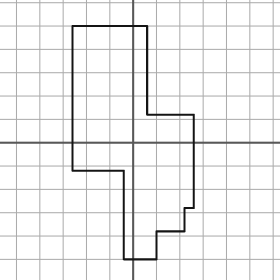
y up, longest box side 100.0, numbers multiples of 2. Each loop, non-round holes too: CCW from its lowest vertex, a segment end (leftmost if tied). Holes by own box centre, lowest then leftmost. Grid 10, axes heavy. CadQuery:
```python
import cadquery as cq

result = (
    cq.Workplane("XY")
    .moveTo(-4.0, -50.0)
    .lineTo(10.0, -50.0)
    .lineTo(10.0, -38.0)
    .lineTo(22.0, -38.0)
    .lineTo(22.0, -28.0)
    .lineTo(26.0, -28.0)
    .lineTo(26.0, 12.0)
    .lineTo(6.0, 12.0)
    .lineTo(6.0, 50.0)
    .lineTo(-26.0, 50.0)
    .lineTo(-26.0, -12.0)
    .lineTo(-4.0, -12.0)
    .close()
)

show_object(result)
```